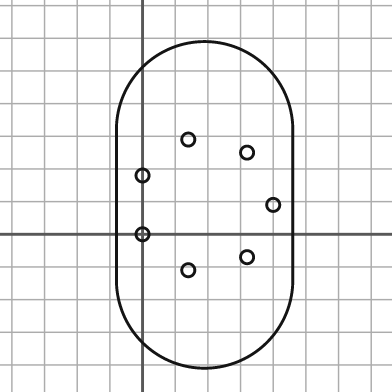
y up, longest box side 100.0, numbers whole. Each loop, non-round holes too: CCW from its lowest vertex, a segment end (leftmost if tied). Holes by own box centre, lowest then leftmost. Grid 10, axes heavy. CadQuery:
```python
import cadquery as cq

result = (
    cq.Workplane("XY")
    .moveTo(-8.0, -14.0)
    .threePointArc((19.0, -41.0), (46.0, -14.0))
    .lineTo(46.0, 32.0)
    .threePointArc((19.0, 59.0), (-8.0, 32.0))
    .close()
    .moveTo(14.0, -11.0)
    .circle(2.0)
    .moveTo(32.0, -7.0)
    .circle(2.0)
    .moveTo(0.0, 0.0)
    .circle(2.0)
    .moveTo(40.0, 9.0)
    .circle(2.0)
    .moveTo(0.0, 18.0)
    .circle(2.0)
    .moveTo(32.0, 25.0)
    .circle(2.0)
    .moveTo(14.0, 29.0)
    .circle(2.0)
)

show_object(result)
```